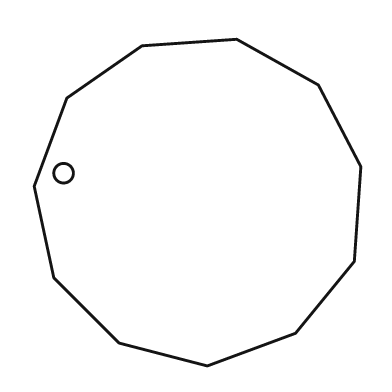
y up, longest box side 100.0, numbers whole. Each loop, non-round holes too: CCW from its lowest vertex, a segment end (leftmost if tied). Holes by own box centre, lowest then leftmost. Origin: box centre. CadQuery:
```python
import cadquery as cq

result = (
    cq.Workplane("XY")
    .moveTo(3.0, -50.0)
    .lineTo(30.0, -40.0)
    .lineTo(48.0, -18.0)
    .lineTo(50.0, 11.0)
    .lineTo(37.0, 36.0)
    .lineTo(12.0, 50.0)
    .lineTo(-17.0, 48.0)
    .lineTo(-40.0, 32.0)
    .lineTo(-50.0, 5.0)
    .lineTo(-44.0, -23.0)
    .lineTo(-24.0, -43.0)
    .close()
    .moveTo(-41.0, 9.0)
    .circle(3.0)
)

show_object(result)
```